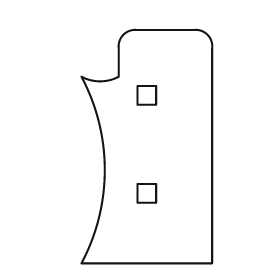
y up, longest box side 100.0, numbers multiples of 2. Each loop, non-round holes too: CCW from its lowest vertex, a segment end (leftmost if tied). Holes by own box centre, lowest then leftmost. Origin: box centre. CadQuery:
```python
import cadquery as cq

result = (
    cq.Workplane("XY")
    .moveTo(-28.0, -50.0)
    .lineTo(28.0, -50.0)
    .lineTo(28.0, 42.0)
    .threePointArc((26.0, 48.0), (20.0, 50.0))
    .lineTo(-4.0, 50.0)
    .threePointArc((-10.0, 48.0), (-12.0, 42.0))
    .lineTo(-12.0, 30.0)
    .threePointArc((-20.0, 28.0), (-28.0, 30.0))
    .threePointArc((-18.0, -10.0), (-28.0, -50.0))
    .close()
    .moveTo(-4.0, -24.0)
    .lineTo(4.0, -24.0)
    .lineTo(4.0, -16.0)
    .lineTo(-4.0, -16.0)
    .close()
    .moveTo(-4.0, 18.0)
    .lineTo(4.0, 18.0)
    .lineTo(4.0, 26.0)
    .lineTo(-4.0, 26.0)
    .close()
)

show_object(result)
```